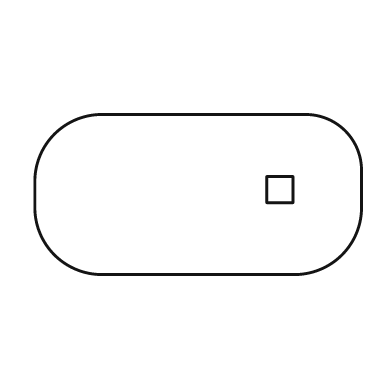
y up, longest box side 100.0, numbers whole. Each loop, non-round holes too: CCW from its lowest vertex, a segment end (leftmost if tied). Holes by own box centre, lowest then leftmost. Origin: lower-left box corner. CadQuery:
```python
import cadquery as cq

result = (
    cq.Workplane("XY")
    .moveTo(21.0, 0.0)
    .lineTo(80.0, 0.0)
    .threePointArc((94.0, 6.0), (100.0, 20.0))
    .lineTo(100.0, 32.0)
    .threePointArc((95.0, 44.0), (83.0, 49.0))
    .lineTo(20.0, 49.0)
    .threePointArc((6.0, 43.0), (0.0, 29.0))
    .lineTo(0.0, 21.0)
    .threePointArc((6.0, 6.0), (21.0, 0.0))
    .close()
    .moveTo(71.0, 22.0)
    .lineTo(79.0, 22.0)
    .lineTo(79.0, 30.0)
    .lineTo(71.0, 30.0)
    .close()
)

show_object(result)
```